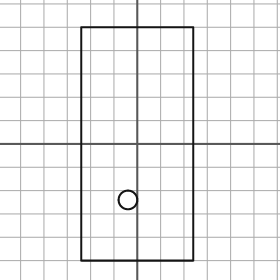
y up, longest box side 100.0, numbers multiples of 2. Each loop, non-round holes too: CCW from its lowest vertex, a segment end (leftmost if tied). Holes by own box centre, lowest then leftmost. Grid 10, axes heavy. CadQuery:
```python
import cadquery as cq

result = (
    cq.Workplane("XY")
    .moveTo(-24.0, -50.0)
    .lineTo(24.0, -50.0)
    .lineTo(24.0, 50.0)
    .lineTo(-24.0, 50.0)
    .close()
    .moveTo(-4.0, -24.0)
    .circle(4.0)
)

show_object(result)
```